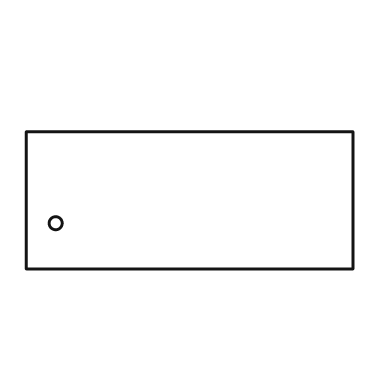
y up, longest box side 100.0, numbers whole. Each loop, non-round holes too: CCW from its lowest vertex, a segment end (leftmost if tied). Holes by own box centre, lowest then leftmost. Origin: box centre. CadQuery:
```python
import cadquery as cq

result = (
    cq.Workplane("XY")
    .moveTo(-50.0, -21.0)
    .lineTo(50.0, -21.0)
    .lineTo(50.0, 21.0)
    .lineTo(-50.0, 21.0)
    .close()
    .moveTo(-41.0, -7.0)
    .circle(2.0)
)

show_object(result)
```